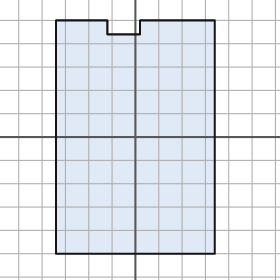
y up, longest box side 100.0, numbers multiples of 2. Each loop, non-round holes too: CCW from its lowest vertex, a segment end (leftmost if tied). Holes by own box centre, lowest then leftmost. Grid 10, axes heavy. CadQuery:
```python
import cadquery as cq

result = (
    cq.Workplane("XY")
    .moveTo(-34.0, -50.0)
    .lineTo(34.0, -50.0)
    .lineTo(34.0, 50.0)
    .lineTo(2.0, 50.0)
    .lineTo(2.0, 44.0)
    .lineTo(-12.0, 44.0)
    .lineTo(-12.0, 50.0)
    .lineTo(-34.0, 50.0)
    .close()
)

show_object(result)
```